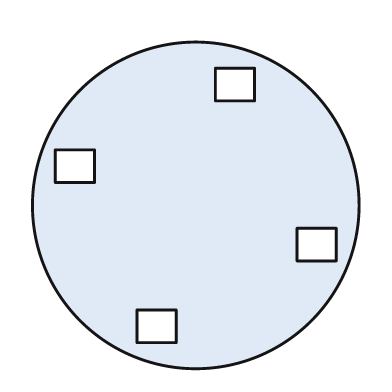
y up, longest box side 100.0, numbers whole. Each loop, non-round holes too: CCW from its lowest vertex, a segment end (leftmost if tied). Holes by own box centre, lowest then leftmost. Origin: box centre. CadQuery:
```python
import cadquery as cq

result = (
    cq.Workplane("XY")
    .moveTo(0.0, 0.0)
    .circle(50.0)
    .moveTo(-18.0, -42.0)
    .lineTo(-6.0, -42.0)
    .lineTo(-6.0, -32.0)
    .lineTo(-18.0, -32.0)
    .close()
    .moveTo(31.0, -17.0)
    .lineTo(43.0, -17.0)
    .lineTo(43.0, -7.0)
    .lineTo(31.0, -7.0)
    .close()
    .moveTo(-43.0, 7.0)
    .lineTo(-31.0, 7.0)
    .lineTo(-31.0, 17.0)
    .lineTo(-43.0, 17.0)
    .close()
    .moveTo(6.0, 32.0)
    .lineTo(18.0, 32.0)
    .lineTo(18.0, 42.0)
    .lineTo(6.0, 42.0)
    .close()
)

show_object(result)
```